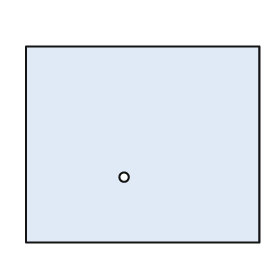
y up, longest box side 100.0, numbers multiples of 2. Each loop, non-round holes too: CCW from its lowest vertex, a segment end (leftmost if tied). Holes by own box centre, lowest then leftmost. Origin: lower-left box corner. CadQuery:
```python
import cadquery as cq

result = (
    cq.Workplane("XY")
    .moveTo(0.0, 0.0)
    .lineTo(100.0, 0.0)
    .lineTo(100.0, 84.0)
    .lineTo(0.0, 84.0)
    .close()
    .moveTo(42.0, 28.0)
    .circle(2.0)
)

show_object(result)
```